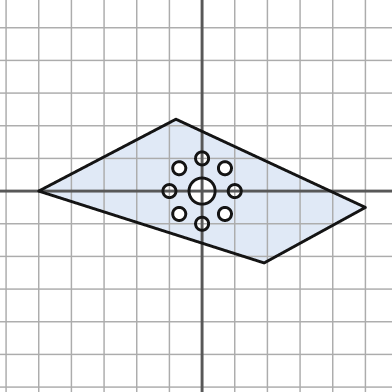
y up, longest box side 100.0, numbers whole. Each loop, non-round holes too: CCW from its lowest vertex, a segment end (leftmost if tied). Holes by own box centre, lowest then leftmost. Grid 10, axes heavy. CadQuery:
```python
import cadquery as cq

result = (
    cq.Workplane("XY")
    .moveTo(19.0, -22.0)
    .lineTo(50.0, -5.0)
    .lineTo(-8.0, 22.0)
    .lineTo(-50.0, 0.0)
    .close()
    .moveTo(0.0, -10.0)
    .circle(2.0)
    .moveTo(-7.0, -7.0)
    .circle(2.0)
    .moveTo(7.0, -7.0)
    .circle(2.0)
    .moveTo(-10.0, 0.0)
    .circle(2.0)
    .moveTo(0.0, 0.0)
    .circle(4.0)
    .moveTo(10.0, 0.0)
    .circle(2.0)
    .moveTo(-7.0, 7.0)
    .circle(2.0)
    .moveTo(7.0, 7.0)
    .circle(2.0)
    .moveTo(0.0, 10.0)
    .circle(2.0)
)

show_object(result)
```